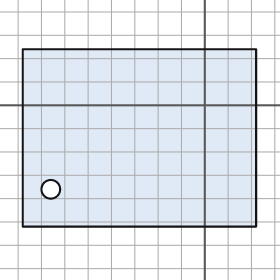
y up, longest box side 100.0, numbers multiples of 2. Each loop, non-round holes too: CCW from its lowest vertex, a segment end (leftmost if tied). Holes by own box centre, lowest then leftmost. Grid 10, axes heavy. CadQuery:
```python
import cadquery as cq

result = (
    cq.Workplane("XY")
    .moveTo(-78.0, -52.0)
    .lineTo(22.0, -52.0)
    .lineTo(22.0, 24.0)
    .lineTo(-78.0, 24.0)
    .close()
    .moveTo(-66.0, -36.0)
    .circle(4.0)
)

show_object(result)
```